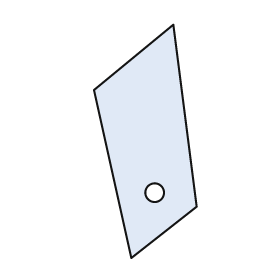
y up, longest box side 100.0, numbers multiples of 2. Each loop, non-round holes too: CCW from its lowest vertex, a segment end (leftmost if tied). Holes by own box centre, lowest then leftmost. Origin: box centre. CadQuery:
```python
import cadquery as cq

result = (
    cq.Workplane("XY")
    .moveTo(-6.0, -50.0)
    .lineTo(22.0, -28.0)
    .lineTo(12.0, 50.0)
    .lineTo(-22.0, 22.0)
    .close()
    .moveTo(4.0, -22.0)
    .circle(4.0)
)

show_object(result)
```